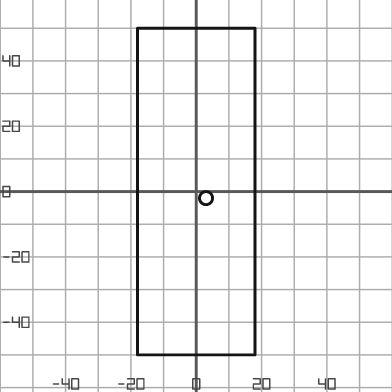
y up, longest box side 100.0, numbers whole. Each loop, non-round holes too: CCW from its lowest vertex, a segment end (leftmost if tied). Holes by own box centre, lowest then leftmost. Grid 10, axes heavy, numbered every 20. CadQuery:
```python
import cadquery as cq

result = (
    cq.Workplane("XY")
    .moveTo(-18.0, -50.0)
    .lineTo(18.0, -50.0)
    .lineTo(18.0, 50.0)
    .lineTo(-18.0, 50.0)
    .close()
    .moveTo(3.0, -2.0)
    .circle(2.0)
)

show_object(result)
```